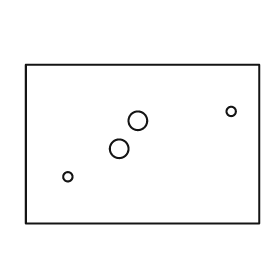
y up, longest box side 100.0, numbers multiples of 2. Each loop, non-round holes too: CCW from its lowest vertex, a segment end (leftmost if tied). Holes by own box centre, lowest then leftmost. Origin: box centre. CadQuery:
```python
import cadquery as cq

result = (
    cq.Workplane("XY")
    .moveTo(-50.0, -34.0)
    .lineTo(50.0, -34.0)
    .lineTo(50.0, 34.0)
    .lineTo(-50.0, 34.0)
    .close()
    .moveTo(-32.0, -14.0)
    .circle(2.0)
    .moveTo(-10.0, -2.0)
    .circle(4.0)
    .moveTo(-2.0, 10.0)
    .circle(4.0)
    .moveTo(38.0, 14.0)
    .circle(2.0)
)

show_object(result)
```